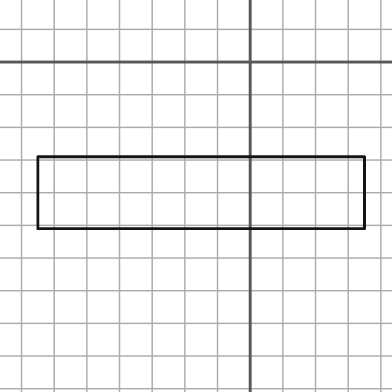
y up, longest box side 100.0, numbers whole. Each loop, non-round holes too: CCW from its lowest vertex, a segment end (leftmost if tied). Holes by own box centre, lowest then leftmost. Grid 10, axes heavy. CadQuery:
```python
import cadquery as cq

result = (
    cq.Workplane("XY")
    .moveTo(-65.0, -51.0)
    .lineTo(35.0, -51.0)
    .lineTo(35.0, -29.0)
    .lineTo(-65.0, -29.0)
    .close()
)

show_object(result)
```